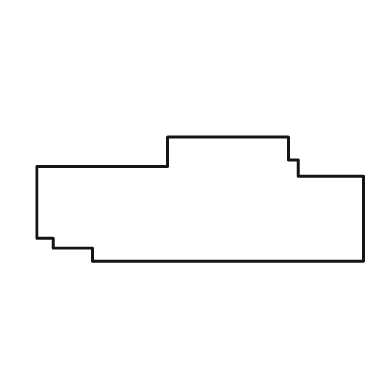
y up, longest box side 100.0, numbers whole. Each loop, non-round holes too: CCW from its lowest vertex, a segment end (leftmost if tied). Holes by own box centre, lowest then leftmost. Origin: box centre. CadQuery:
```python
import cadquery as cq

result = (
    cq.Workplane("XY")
    .moveTo(-33.0, -19.0)
    .lineTo(50.0, -19.0)
    .lineTo(50.0, 7.0)
    .lineTo(30.0, 7.0)
    .lineTo(30.0, 12.0)
    .lineTo(27.0, 12.0)
    .lineTo(27.0, 19.0)
    .lineTo(-10.0, 19.0)
    .lineTo(-10.0, 10.0)
    .lineTo(-50.0, 10.0)
    .lineTo(-50.0, -12.0)
    .lineTo(-45.0, -12.0)
    .lineTo(-45.0, -15.0)
    .lineTo(-33.0, -15.0)
    .close()
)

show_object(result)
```